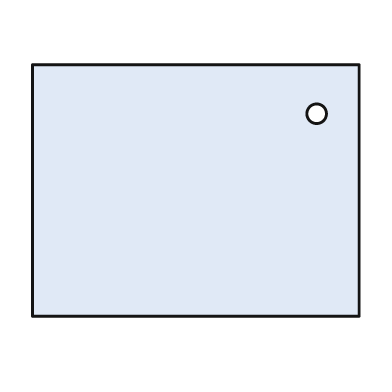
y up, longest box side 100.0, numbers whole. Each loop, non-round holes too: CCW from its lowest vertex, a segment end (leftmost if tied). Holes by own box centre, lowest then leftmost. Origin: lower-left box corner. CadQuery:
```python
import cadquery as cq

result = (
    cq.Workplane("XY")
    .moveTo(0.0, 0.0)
    .lineTo(100.0, 0.0)
    .lineTo(100.0, 77.0)
    .lineTo(0.0, 77.0)
    .close()
    .moveTo(87.0, 62.0)
    .circle(3.0)
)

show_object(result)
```